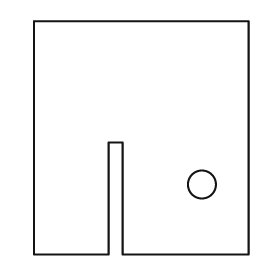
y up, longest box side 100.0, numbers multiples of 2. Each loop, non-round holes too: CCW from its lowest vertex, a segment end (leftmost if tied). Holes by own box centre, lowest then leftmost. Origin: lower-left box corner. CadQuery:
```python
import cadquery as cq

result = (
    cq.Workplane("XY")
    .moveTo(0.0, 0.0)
    .lineTo(32.0, 0.0)
    .lineTo(32.0, 48.0)
    .lineTo(38.0, 48.0)
    .lineTo(38.0, 0.0)
    .lineTo(92.0, 0.0)
    .lineTo(92.0, 100.0)
    .lineTo(0.0, 100.0)
    .close()
    .moveTo(72.0, 30.0)
    .circle(6.0)
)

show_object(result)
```